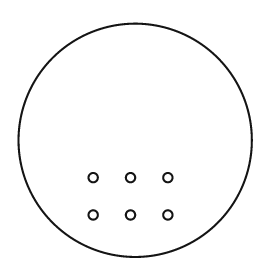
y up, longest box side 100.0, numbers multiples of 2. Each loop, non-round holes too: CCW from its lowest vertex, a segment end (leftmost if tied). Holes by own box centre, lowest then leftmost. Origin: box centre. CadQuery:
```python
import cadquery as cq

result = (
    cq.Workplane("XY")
    .moveTo(0.0, 0.0)
    .circle(50.0)
    .moveTo(-18.0, -32.0)
    .circle(2.0)
    .moveTo(-2.0, -32.0)
    .circle(2.0)
    .moveTo(14.0, -32.0)
    .circle(2.0)
    .moveTo(-18.0, -16.0)
    .circle(2.0)
    .moveTo(-2.0, -16.0)
    .circle(2.0)
    .moveTo(14.0, -16.0)
    .circle(2.0)
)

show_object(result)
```